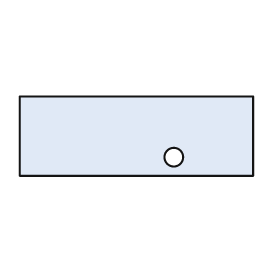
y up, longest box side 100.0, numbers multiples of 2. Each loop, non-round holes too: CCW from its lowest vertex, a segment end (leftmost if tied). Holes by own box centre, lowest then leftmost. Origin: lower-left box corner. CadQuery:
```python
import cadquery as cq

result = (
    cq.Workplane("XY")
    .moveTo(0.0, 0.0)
    .lineTo(100.0, 0.0)
    .lineTo(100.0, 34.0)
    .lineTo(0.0, 34.0)
    .close()
    .moveTo(66.0, 8.0)
    .circle(4.0)
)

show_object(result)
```